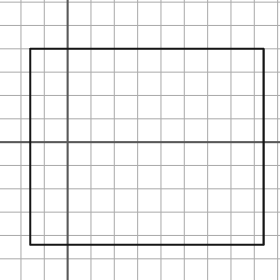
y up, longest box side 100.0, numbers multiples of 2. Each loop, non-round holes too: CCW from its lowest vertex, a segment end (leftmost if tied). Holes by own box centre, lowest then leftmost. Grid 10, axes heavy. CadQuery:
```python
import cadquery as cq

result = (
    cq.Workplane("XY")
    .moveTo(-16.0, -44.0)
    .lineTo(84.0, -44.0)
    .lineTo(84.0, 40.0)
    .lineTo(-16.0, 40.0)
    .close()
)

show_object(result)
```